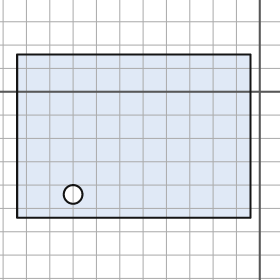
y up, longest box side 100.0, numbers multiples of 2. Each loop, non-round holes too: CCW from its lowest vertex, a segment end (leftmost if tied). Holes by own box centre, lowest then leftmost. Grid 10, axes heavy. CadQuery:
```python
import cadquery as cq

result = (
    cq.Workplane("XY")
    .moveTo(-104.0, -54.0)
    .lineTo(-4.0, -54.0)
    .lineTo(-4.0, 16.0)
    .lineTo(-104.0, 16.0)
    .close()
    .moveTo(-80.0, -44.0)
    .circle(4.0)
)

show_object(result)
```